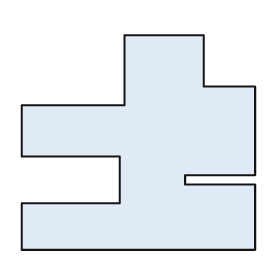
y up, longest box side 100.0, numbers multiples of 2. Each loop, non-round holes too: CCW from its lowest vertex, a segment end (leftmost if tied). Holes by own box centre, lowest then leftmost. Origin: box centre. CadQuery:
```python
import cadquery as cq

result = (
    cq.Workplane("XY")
    .moveTo(-50.0, -46.0)
    .lineTo(50.0, -46.0)
    .lineTo(50.0, -18.0)
    .lineTo(20.0, -18.0)
    .lineTo(20.0, -14.0)
    .lineTo(50.0, -14.0)
    .lineTo(50.0, 24.0)
    .lineTo(28.0, 24.0)
    .lineTo(28.0, 46.0)
    .lineTo(-6.0, 46.0)
    .lineTo(-6.0, 16.0)
    .lineTo(-50.0, 16.0)
    .lineTo(-50.0, -6.0)
    .lineTo(-8.0, -6.0)
    .lineTo(-8.0, -26.0)
    .lineTo(-50.0, -26.0)
    .close()
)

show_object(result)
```